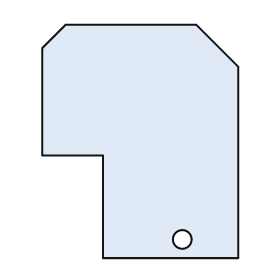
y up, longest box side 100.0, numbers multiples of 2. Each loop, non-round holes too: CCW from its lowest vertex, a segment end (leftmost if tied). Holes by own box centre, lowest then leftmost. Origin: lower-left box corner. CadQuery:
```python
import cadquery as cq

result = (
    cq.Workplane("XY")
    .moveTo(26.0, 0.0)
    .lineTo(84.0, 0.0)
    .lineTo(84.0, 82.0)
    .lineTo(66.0, 100.0)
    .lineTo(10.0, 100.0)
    .lineTo(0.0, 90.0)
    .lineTo(0.0, 44.0)
    .lineTo(26.0, 44.0)
    .close()
    .moveTo(60.0, 8.0)
    .circle(4.0)
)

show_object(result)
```